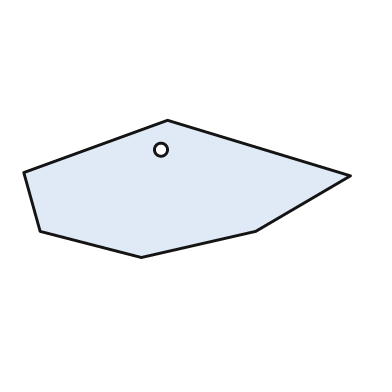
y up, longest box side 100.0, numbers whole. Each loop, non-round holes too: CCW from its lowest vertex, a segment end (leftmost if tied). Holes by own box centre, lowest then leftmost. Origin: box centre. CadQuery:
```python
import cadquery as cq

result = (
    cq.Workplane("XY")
    .moveTo(-14.0, -21.0)
    .lineTo(21.0, -13.0)
    .lineTo(50.0, 4.0)
    .lineTo(-6.0, 21.0)
    .lineTo(-50.0, 5.0)
    .lineTo(-45.0, -13.0)
    .close()
    .moveTo(-8.0, 12.0)
    .circle(2.0)
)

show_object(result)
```